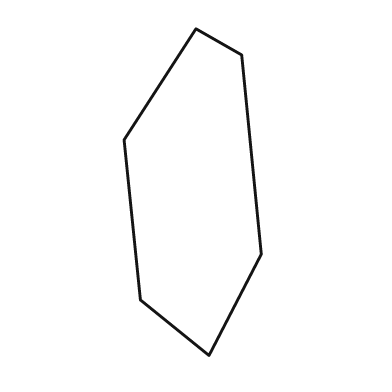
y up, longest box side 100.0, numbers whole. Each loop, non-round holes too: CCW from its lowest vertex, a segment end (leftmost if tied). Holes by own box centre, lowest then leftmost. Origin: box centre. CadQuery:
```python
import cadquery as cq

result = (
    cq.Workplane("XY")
    .moveTo(5.0, -50.0)
    .lineTo(21.0, -19.0)
    .lineTo(15.0, 42.0)
    .lineTo(1.0, 50.0)
    .lineTo(-21.0, 16.0)
    .lineTo(-16.0, -33.0)
    .close()
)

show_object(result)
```